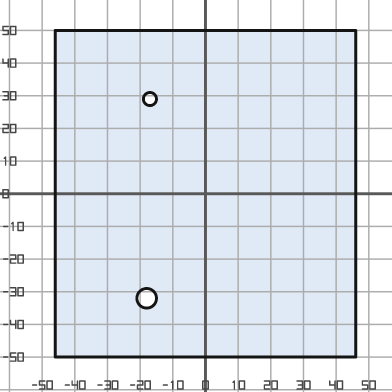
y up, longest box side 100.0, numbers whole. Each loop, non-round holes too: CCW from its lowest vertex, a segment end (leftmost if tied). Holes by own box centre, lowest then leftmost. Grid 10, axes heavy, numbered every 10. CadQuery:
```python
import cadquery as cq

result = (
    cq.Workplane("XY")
    .moveTo(-46.0, -50.0)
    .lineTo(46.0, -50.0)
    .lineTo(46.0, 50.0)
    .lineTo(-46.0, 50.0)
    .close()
    .moveTo(-18.0, -32.0)
    .circle(3.0)
    .moveTo(-17.0, 29.0)
    .circle(2.0)
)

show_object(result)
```